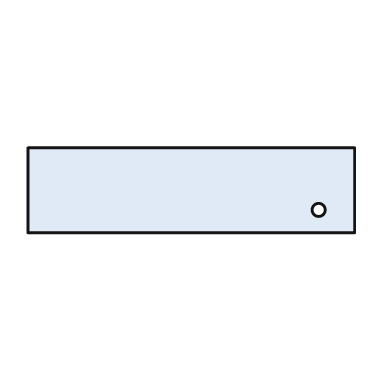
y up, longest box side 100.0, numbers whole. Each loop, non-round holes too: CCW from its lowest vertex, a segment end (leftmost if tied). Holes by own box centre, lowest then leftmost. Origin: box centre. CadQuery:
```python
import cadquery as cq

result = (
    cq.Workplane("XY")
    .moveTo(-50.0, -13.0)
    .lineTo(50.0, -13.0)
    .lineTo(50.0, 13.0)
    .lineTo(-50.0, 13.0)
    .close()
    .moveTo(39.0, -6.0)
    .circle(2.0)
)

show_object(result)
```